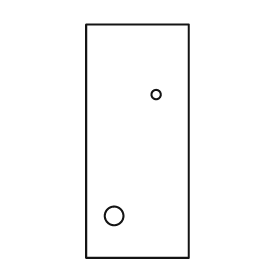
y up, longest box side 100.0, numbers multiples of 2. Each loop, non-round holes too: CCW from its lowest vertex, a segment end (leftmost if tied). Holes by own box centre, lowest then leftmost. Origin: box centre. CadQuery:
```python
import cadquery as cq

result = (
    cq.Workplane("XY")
    .moveTo(-22.0, -50.0)
    .lineTo(22.0, -50.0)
    .lineTo(22.0, 50.0)
    .lineTo(-22.0, 50.0)
    .close()
    .moveTo(-10.0, -32.0)
    .circle(4.0)
    .moveTo(8.0, 20.0)
    .circle(2.0)
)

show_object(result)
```